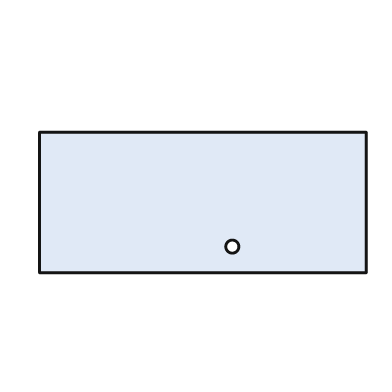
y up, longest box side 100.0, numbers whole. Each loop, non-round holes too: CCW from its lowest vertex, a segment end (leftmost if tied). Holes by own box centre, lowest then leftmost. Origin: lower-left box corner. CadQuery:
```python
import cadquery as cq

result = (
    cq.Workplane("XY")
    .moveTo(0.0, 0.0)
    .lineTo(100.0, 0.0)
    .lineTo(100.0, 43.0)
    .lineTo(0.0, 43.0)
    .close()
    .moveTo(59.0, 8.0)
    .circle(2.0)
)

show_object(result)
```